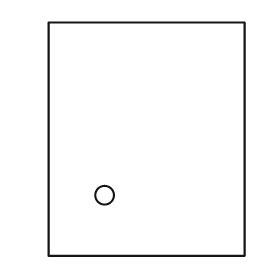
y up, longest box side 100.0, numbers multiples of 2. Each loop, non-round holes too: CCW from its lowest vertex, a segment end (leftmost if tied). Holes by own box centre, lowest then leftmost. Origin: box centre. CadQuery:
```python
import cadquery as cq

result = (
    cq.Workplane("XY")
    .moveTo(-42.0, -50.0)
    .lineTo(42.0, -50.0)
    .lineTo(42.0, 50.0)
    .lineTo(-42.0, 50.0)
    .close()
    .moveTo(-18.0, -24.0)
    .circle(4.0)
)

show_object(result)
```